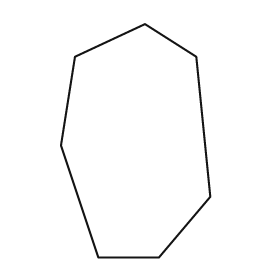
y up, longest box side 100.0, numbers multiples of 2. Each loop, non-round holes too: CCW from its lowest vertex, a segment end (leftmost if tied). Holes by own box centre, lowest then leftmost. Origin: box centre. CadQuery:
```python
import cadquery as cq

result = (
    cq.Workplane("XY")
    .moveTo(-16.0, -50.0)
    .lineTo(10.0, -50.0)
    .lineTo(32.0, -24.0)
    .lineTo(26.0, 36.0)
    .lineTo(4.0, 50.0)
    .lineTo(-26.0, 36.0)
    .lineTo(-32.0, -2.0)
    .close()
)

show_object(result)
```